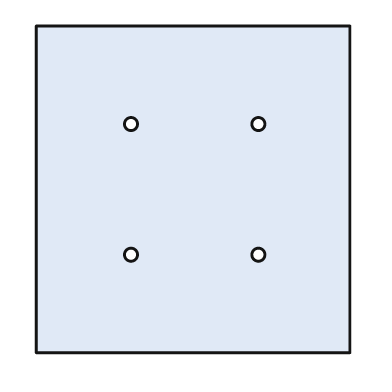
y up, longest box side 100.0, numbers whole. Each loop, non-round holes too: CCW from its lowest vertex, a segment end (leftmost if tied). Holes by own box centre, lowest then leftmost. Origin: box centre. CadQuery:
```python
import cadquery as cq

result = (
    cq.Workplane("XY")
    .moveTo(-48.0, -50.0)
    .lineTo(48.0, -50.0)
    .lineTo(48.0, 50.0)
    .lineTo(-48.0, 50.0)
    .close()
    .moveTo(-19.0, -20.0)
    .circle(2.0)
    .moveTo(20.0, -20.0)
    .circle(2.0)
    .moveTo(-19.0, 20.0)
    .circle(2.0)
    .moveTo(20.0, 20.0)
    .circle(2.0)
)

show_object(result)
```